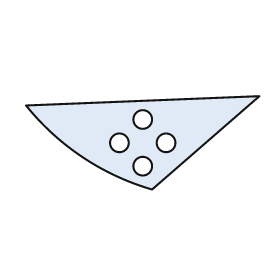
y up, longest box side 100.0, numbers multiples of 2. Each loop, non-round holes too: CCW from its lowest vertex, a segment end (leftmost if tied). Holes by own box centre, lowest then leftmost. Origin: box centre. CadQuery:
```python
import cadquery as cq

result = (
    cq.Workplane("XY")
    .moveTo(4.0, -20.0)
    .lineTo(50.0, 20.0)
    .lineTo(-50.0, 16.0)
    .threePointArc((-26.0, -6.0), (4.0, -20.0))
    .close()
    .moveTo(0.0, -10.0)
    .circle(4.0)
    .moveTo(-10.0, 0.0)
    .circle(4.0)
    .moveTo(10.0, 0.0)
    .circle(4.0)
    .moveTo(0.0, 10.0)
    .circle(4.0)
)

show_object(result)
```